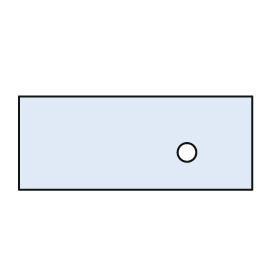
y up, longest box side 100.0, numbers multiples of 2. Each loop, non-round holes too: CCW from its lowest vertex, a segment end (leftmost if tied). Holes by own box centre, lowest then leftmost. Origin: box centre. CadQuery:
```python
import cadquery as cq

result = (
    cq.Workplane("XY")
    .moveTo(-50.0, -20.0)
    .lineTo(50.0, -20.0)
    .lineTo(50.0, 20.0)
    .lineTo(-50.0, 20.0)
    .close()
    .moveTo(22.0, -4.0)
    .circle(4.0)
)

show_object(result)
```